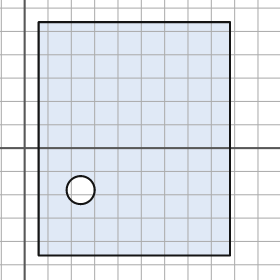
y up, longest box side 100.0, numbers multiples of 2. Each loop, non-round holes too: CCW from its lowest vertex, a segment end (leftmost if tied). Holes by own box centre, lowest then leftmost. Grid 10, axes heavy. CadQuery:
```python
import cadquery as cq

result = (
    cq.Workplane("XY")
    .moveTo(6.0, -46.0)
    .lineTo(88.0, -46.0)
    .lineTo(88.0, 54.0)
    .lineTo(6.0, 54.0)
    .close()
    .moveTo(24.0, -18.0)
    .circle(6.0)
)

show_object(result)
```